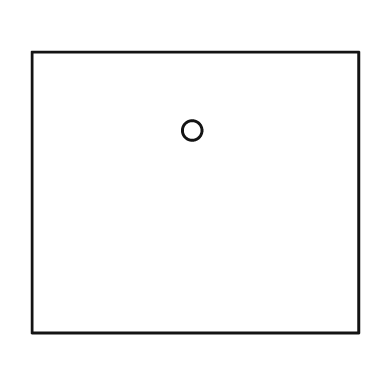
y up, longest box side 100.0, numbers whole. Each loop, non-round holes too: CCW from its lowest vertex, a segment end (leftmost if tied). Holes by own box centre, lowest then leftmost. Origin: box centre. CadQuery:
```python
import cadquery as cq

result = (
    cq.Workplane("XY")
    .moveTo(-50.0, -43.0)
    .lineTo(50.0, -43.0)
    .lineTo(50.0, 43.0)
    .lineTo(-50.0, 43.0)
    .close()
    .moveTo(-1.0, 19.0)
    .circle(3.0)
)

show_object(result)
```